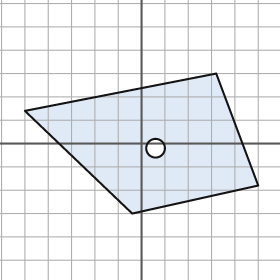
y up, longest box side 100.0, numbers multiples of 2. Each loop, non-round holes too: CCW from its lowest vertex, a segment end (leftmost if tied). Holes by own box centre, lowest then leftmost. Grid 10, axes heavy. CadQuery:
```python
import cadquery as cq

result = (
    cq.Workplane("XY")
    .moveTo(-4.0, -30.0)
    .lineTo(50.0, -18.0)
    .lineTo(32.0, 30.0)
    .lineTo(-50.0, 14.0)
    .close()
    .moveTo(6.0, -2.0)
    .circle(4.0)
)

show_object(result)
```